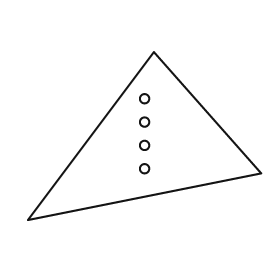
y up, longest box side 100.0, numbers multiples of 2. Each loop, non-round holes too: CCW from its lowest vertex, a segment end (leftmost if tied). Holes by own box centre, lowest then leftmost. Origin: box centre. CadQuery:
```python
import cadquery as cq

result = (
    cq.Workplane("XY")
    .moveTo(-50.0, -36.0)
    .lineTo(50.0, -16.0)
    .lineTo(4.0, 36.0)
    .close()
    .moveTo(0.0, -14.0)
    .circle(2.0)
    .moveTo(0.0, -4.0)
    .circle(2.0)
    .moveTo(0.0, 6.0)
    .circle(2.0)
    .moveTo(0.0, 16.0)
    .circle(2.0)
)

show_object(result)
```